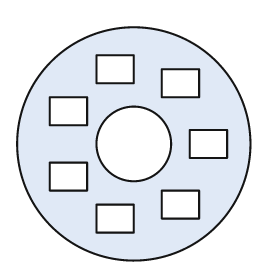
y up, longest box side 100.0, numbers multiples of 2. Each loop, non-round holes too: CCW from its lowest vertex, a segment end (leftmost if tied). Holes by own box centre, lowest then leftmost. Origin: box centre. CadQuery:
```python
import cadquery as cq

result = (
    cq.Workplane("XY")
    .moveTo(0.0, 0.0)
    .circle(50.0)
    .moveTo(-16.0, -38.0)
    .lineTo(0.0, -38.0)
    .lineTo(0.0, -26.0)
    .lineTo(-16.0, -26.0)
    .close()
    .moveTo(12.0, -32.0)
    .lineTo(28.0, -32.0)
    .lineTo(28.0, -20.0)
    .lineTo(12.0, -20.0)
    .close()
    .moveTo(-36.0, -20.0)
    .lineTo(-20.0, -20.0)
    .lineTo(-20.0, -8.0)
    .lineTo(-36.0, -8.0)
    .close()
    .moveTo(0.0, 0.0)
    .circle(16.0)
    .moveTo(24.0, -6.0)
    .lineTo(40.0, -6.0)
    .lineTo(40.0, 6.0)
    .lineTo(24.0, 6.0)
    .close()
    .moveTo(-36.0, 8.0)
    .lineTo(-20.0, 8.0)
    .lineTo(-20.0, 20.0)
    .lineTo(-36.0, 20.0)
    .close()
    .moveTo(12.0, 20.0)
    .lineTo(28.0, 20.0)
    .lineTo(28.0, 32.0)
    .lineTo(12.0, 32.0)
    .close()
    .moveTo(-16.0, 26.0)
    .lineTo(0.0, 26.0)
    .lineTo(0.0, 38.0)
    .lineTo(-16.0, 38.0)
    .close()
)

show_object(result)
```